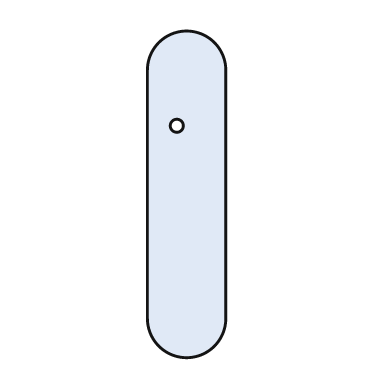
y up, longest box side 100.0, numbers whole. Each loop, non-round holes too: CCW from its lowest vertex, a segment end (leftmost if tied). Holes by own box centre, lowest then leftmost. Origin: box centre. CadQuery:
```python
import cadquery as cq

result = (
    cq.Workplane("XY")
    .moveTo(-12.0, -38.0)
    .threePointArc((0.0, -50.0), (12.0, -38.0))
    .lineTo(12.0, 38.0)
    .threePointArc((0.0, 50.0), (-12.0, 38.0))
    .close()
    .moveTo(-3.0, 21.0)
    .circle(2.0)
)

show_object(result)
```